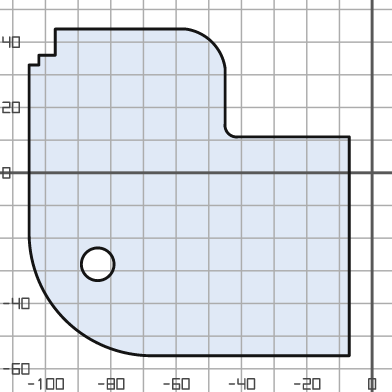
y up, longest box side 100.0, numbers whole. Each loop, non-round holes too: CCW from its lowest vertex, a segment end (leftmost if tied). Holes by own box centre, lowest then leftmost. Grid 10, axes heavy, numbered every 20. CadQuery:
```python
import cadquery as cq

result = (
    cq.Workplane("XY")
    .moveTo(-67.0, -56.0)
    .lineTo(-7.0, -56.0)
    .lineTo(-7.0, 11.0)
    .lineTo(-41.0, 11.0)
    .threePointArc((-44.0, 12.0), (-45.0, 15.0))
    .lineTo(-45.0, 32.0)
    .threePointArc((-49.0, 40.0), (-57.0, 44.0))
    .lineTo(-97.0, 44.0)
    .lineTo(-97.0, 36.0)
    .lineTo(-102.0, 36.0)
    .lineTo(-102.0, 33.0)
    .lineTo(-105.0, 33.0)
    .lineTo(-105.0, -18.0)
    .threePointArc((-94.0, -45.0), (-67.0, -56.0))
    .close()
    .moveTo(-84.0, -28.0)
    .circle(5.0)
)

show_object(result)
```